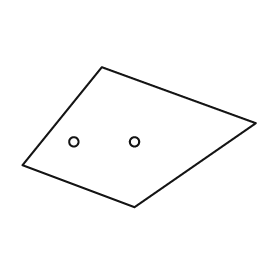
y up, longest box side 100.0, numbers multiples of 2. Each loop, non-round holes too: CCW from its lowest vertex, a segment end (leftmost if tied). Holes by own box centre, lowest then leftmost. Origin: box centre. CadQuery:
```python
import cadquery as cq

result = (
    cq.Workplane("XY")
    .moveTo(-2.0, -30.0)
    .lineTo(50.0, 6.0)
    .lineTo(-16.0, 30.0)
    .lineTo(-50.0, -12.0)
    .close()
    .moveTo(-28.0, -2.0)
    .circle(2.0)
    .moveTo(-2.0, -2.0)
    .circle(2.0)
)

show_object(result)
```